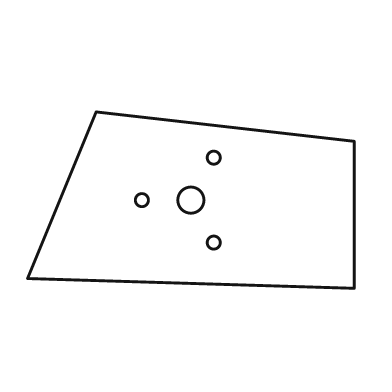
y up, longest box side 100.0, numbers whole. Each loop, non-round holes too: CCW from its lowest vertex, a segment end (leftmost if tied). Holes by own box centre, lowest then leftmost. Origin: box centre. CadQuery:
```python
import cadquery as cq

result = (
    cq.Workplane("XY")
    .moveTo(50.0, -27.0)
    .lineTo(50.0, 18.0)
    .lineTo(-29.0, 27.0)
    .lineTo(-50.0, -24.0)
    .close()
    .moveTo(7.0, -13.0)
    .circle(2.0)
    .moveTo(-15.0, 0.0)
    .circle(2.0)
    .moveTo(0.0, 0.0)
    .circle(4.0)
    .moveTo(7.0, 13.0)
    .circle(2.0)
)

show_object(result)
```